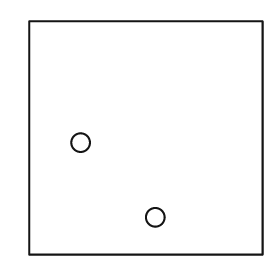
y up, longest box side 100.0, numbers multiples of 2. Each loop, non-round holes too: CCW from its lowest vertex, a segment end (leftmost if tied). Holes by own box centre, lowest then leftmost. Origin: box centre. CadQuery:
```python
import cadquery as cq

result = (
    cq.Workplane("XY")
    .moveTo(-50.0, -50.0)
    .lineTo(50.0, -50.0)
    .lineTo(50.0, 50.0)
    .lineTo(-50.0, 50.0)
    .close()
    .moveTo(4.0, -34.0)
    .circle(4.0)
    .moveTo(-28.0, -2.0)
    .circle(4.0)
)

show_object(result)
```